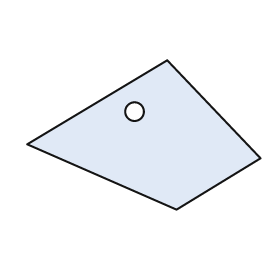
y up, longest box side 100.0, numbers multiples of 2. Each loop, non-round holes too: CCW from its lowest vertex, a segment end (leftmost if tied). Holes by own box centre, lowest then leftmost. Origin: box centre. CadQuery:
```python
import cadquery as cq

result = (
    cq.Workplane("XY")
    .moveTo(14.0, -32.0)
    .lineTo(50.0, -10.0)
    .lineTo(10.0, 32.0)
    .lineTo(-50.0, -4.0)
    .close()
    .moveTo(-4.0, 10.0)
    .circle(4.0)
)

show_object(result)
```